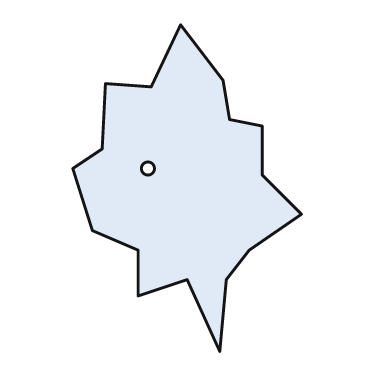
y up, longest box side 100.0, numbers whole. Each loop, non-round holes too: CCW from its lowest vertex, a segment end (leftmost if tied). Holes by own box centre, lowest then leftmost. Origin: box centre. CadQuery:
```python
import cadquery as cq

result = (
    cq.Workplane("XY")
    .moveTo(10.0, -50.0)
    .lineTo(12.0, -28.0)
    .lineTo(19.0, -19.0)
    .lineTo(35.0, -8.0)
    .lineTo(23.0, 4.0)
    .lineTo(23.0, 19.0)
    .lineTo(13.0, 21.0)
    .lineTo(11.0, 33.0)
    .lineTo(-2.0, 50.0)
    .lineTo(-11.0, 31.0)
    .lineTo(-25.0, 32.0)
    .lineTo(-26.0, 12.0)
    .lineTo(-35.0, 6.0)
    .lineTo(-29.0, -13.0)
    .lineTo(-15.0, -19.0)
    .lineTo(-15.0, -33.0)
    .lineTo(0.0, -28.0)
    .close()
    .moveTo(-12.0, 6.0)
    .circle(2.0)
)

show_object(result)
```